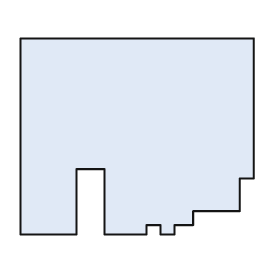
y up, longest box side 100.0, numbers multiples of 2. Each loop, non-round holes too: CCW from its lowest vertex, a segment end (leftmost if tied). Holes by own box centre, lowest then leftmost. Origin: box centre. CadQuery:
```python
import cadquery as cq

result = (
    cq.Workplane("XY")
    .moveTo(-50.0, -42.0)
    .lineTo(-26.0, -42.0)
    .lineTo(-26.0, -14.0)
    .lineTo(-14.0, -14.0)
    .lineTo(-14.0, -42.0)
    .lineTo(4.0, -42.0)
    .lineTo(4.0, -38.0)
    .lineTo(10.0, -38.0)
    .lineTo(10.0, -42.0)
    .lineTo(16.0, -42.0)
    .lineTo(16.0, -38.0)
    .lineTo(24.0, -38.0)
    .lineTo(24.0, -32.0)
    .lineTo(44.0, -32.0)
    .lineTo(44.0, -18.0)
    .lineTo(50.0, -18.0)
    .lineTo(50.0, 42.0)
    .lineTo(-50.0, 42.0)
    .close()
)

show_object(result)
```